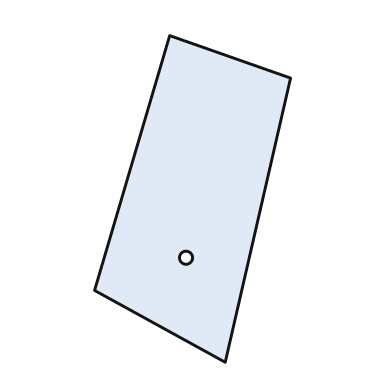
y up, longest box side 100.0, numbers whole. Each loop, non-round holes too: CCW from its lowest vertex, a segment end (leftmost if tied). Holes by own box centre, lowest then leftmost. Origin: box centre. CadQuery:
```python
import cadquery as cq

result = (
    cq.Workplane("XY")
    .moveTo(10.0, -50.0)
    .lineTo(30.0, 37.0)
    .lineTo(-7.0, 50.0)
    .lineTo(-30.0, -28.0)
    .close()
    .moveTo(-2.0, -18.0)
    .circle(2.0)
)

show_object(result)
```